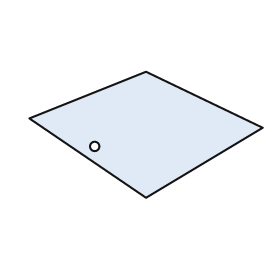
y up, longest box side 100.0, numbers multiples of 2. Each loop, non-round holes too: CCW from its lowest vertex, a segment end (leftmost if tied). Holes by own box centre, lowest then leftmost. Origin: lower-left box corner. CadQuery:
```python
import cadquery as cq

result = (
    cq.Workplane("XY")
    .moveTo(50.0, 0.0)
    .lineTo(100.0, 30.0)
    .lineTo(50.0, 54.0)
    .lineTo(0.0, 34.0)
    .close()
    .moveTo(28.0, 22.0)
    .circle(2.0)
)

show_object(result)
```